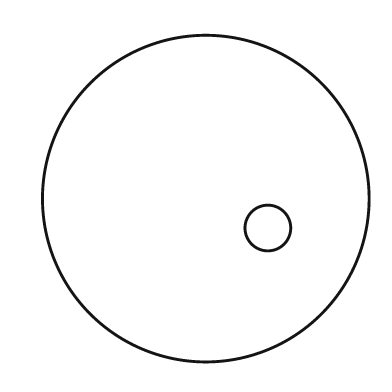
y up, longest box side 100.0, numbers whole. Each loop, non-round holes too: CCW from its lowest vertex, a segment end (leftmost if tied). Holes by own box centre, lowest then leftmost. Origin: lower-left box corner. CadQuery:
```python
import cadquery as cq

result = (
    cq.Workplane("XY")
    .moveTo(50.0, 50.0)
    .circle(50.0)
    .moveTo(69.0, 41.0)
    .circle(7.0)
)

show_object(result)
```